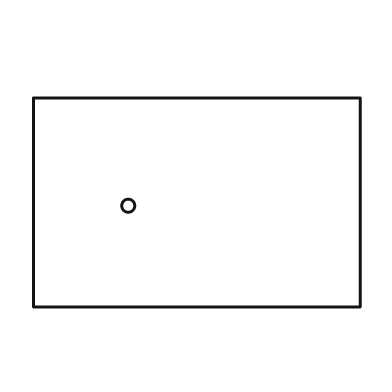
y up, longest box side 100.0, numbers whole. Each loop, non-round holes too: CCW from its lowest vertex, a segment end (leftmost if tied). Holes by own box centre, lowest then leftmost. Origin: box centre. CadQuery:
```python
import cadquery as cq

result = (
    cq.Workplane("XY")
    .moveTo(-50.0, -32.0)
    .lineTo(50.0, -32.0)
    .lineTo(50.0, 32.0)
    .lineTo(-50.0, 32.0)
    .close()
    .moveTo(-21.0, -1.0)
    .circle(2.0)
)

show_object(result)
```